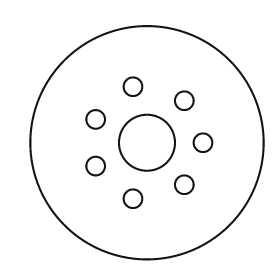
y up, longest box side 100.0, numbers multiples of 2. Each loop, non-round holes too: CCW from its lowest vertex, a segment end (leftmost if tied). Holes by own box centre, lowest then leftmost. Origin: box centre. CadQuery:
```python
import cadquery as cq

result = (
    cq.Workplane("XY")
    .moveTo(0.0, 0.0)
    .circle(50.0)
    .moveTo(-6.0, -24.0)
    .circle(4.0)
    .moveTo(16.0, -18.0)
    .circle(4.0)
    .moveTo(-22.0, -10.0)
    .circle(4.0)
    .moveTo(0.0, 0.0)
    .circle(12.0)
    .moveTo(24.0, 0.0)
    .circle(4.0)
    .moveTo(-22.0, 10.0)
    .circle(4.0)
    .moveTo(16.0, 18.0)
    .circle(4.0)
    .moveTo(-6.0, 24.0)
    .circle(4.0)
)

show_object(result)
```